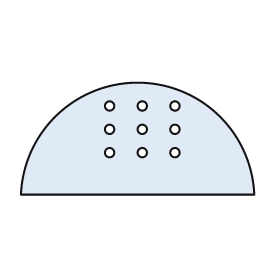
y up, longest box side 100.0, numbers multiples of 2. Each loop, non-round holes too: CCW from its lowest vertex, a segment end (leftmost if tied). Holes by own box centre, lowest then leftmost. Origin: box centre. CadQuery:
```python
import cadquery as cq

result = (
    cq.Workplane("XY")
    .moveTo(-50.0, -24.0)
    .lineTo(50.0, -24.0)
    .threePointArc((0.0, 24.0), (-50.0, -24.0))
    .close()
    .moveTo(-12.0, -6.0)
    .circle(2.0)
    .moveTo(2.0, -6.0)
    .circle(2.0)
    .moveTo(16.0, -6.0)
    .circle(2.0)
    .moveTo(-12.0, 4.0)
    .circle(2.0)
    .moveTo(2.0, 4.0)
    .circle(2.0)
    .moveTo(16.0, 4.0)
    .circle(2.0)
    .moveTo(-12.0, 14.0)
    .circle(2.0)
    .moveTo(2.0, 14.0)
    .circle(2.0)
    .moveTo(16.0, 14.0)
    .circle(2.0)
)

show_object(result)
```